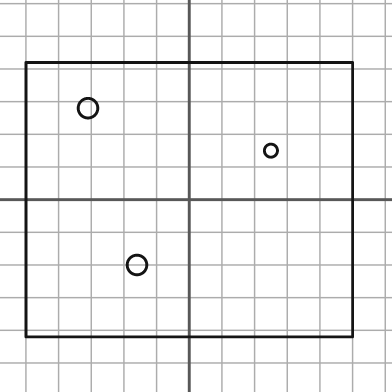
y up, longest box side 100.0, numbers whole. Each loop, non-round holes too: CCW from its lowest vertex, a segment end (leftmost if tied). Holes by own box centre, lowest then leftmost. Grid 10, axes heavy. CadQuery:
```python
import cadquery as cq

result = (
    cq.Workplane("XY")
    .moveTo(-50.0, -42.0)
    .lineTo(50.0, -42.0)
    .lineTo(50.0, 42.0)
    .lineTo(-50.0, 42.0)
    .close()
    .moveTo(-16.0, -20.0)
    .circle(3.0)
    .moveTo(25.0, 15.0)
    .circle(2.0)
    .moveTo(-31.0, 28.0)
    .circle(3.0)
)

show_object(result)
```